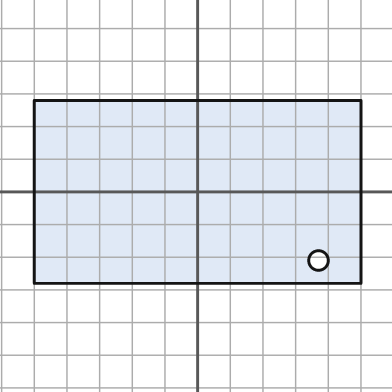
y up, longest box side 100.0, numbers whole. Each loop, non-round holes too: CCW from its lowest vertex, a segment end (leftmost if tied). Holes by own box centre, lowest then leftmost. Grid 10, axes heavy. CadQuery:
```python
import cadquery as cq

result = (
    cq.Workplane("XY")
    .moveTo(-50.0, -28.0)
    .lineTo(50.0, -28.0)
    .lineTo(50.0, 28.0)
    .lineTo(-50.0, 28.0)
    .close()
    .moveTo(37.0, -21.0)
    .circle(3.0)
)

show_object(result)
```